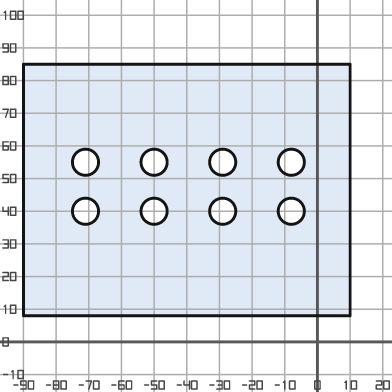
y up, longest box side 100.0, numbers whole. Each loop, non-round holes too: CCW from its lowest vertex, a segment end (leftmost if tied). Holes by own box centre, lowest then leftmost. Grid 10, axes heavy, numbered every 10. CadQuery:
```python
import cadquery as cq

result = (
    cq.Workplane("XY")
    .moveTo(-90.0, 8.0)
    .lineTo(10.0, 8.0)
    .lineTo(10.0, 85.0)
    .lineTo(-90.0, 85.0)
    .close()
    .moveTo(-71.0, 40.0)
    .circle(4.0)
    .moveTo(-50.0, 40.0)
    .circle(4.0)
    .moveTo(-29.0, 40.0)
    .circle(4.0)
    .moveTo(-8.0, 40.0)
    .circle(4.0)
    .moveTo(-71.0, 55.0)
    .circle(4.0)
    .moveTo(-50.0, 55.0)
    .circle(4.0)
    .moveTo(-29.0, 55.0)
    .circle(4.0)
    .moveTo(-8.0, 55.0)
    .circle(4.0)
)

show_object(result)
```